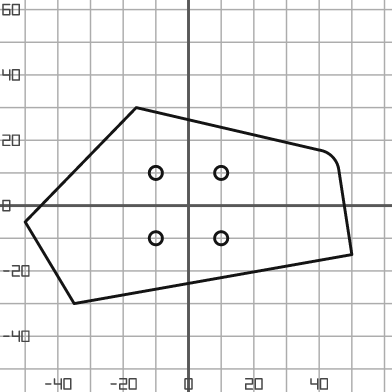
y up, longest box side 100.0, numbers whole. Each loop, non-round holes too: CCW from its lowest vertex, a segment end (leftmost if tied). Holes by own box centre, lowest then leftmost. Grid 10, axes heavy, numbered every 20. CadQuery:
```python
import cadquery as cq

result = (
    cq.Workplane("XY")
    .moveTo(-35.0, -30.0)
    .lineTo(50.0, -15.0)
    .lineTo(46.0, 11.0)
    .threePointArc((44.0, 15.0), (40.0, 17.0))
    .lineTo(-16.0, 30.0)
    .lineTo(-50.0, -5.0)
    .close()
    .moveTo(-10.0, -10.0)
    .circle(2.0)
    .moveTo(10.0, -10.0)
    .circle(2.0)
    .moveTo(-10.0, 10.0)
    .circle(2.0)
    .moveTo(10.0, 10.0)
    .circle(2.0)
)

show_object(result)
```